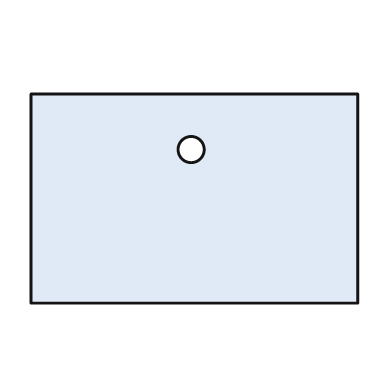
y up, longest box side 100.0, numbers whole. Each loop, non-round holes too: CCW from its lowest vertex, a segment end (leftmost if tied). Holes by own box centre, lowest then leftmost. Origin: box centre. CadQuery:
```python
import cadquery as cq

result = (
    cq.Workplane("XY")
    .moveTo(-50.0, -32.0)
    .lineTo(50.0, -32.0)
    .lineTo(50.0, 32.0)
    .lineTo(-50.0, 32.0)
    .close()
    .moveTo(-1.0, 15.0)
    .circle(4.0)
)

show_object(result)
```